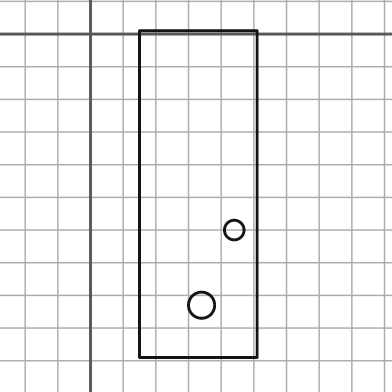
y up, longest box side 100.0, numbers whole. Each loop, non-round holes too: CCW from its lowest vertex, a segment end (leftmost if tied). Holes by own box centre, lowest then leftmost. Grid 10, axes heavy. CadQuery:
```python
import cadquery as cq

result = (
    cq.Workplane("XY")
    .moveTo(15.0, -99.0)
    .lineTo(51.0, -99.0)
    .lineTo(51.0, 1.0)
    .lineTo(15.0, 1.0)
    .close()
    .moveTo(34.0, -83.0)
    .circle(4.0)
    .moveTo(44.0, -60.0)
    .circle(3.0)
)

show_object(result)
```